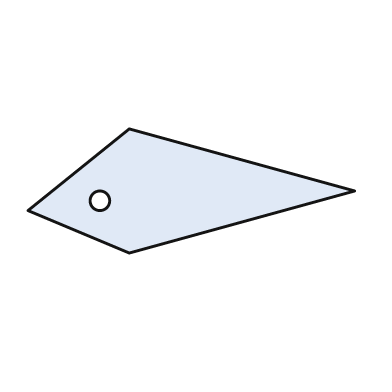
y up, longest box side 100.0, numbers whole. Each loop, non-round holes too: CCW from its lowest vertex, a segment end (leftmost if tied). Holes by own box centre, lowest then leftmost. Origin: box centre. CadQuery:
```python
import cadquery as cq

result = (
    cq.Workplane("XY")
    .moveTo(-19.0, -19.0)
    .lineTo(50.0, 0.0)
    .lineTo(-19.0, 19.0)
    .lineTo(-50.0, -6.0)
    .close()
    .moveTo(-28.0, -3.0)
    .circle(3.0)
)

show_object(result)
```